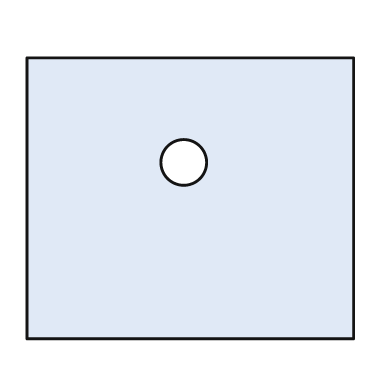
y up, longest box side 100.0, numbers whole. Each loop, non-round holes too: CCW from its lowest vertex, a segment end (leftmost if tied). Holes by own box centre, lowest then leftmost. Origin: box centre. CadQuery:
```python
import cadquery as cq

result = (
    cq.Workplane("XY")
    .moveTo(-50.0, -43.0)
    .lineTo(50.0, -43.0)
    .lineTo(50.0, 43.0)
    .lineTo(-50.0, 43.0)
    .close()
    .moveTo(-2.0, 11.0)
    .circle(7.0)
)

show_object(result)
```